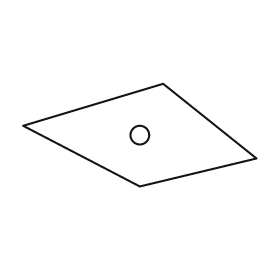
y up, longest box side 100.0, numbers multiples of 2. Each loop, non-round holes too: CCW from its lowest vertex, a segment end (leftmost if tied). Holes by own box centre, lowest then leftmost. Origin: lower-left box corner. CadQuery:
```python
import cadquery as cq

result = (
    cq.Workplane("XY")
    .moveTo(50.0, 0.0)
    .lineTo(100.0, 12.0)
    .lineTo(60.0, 44.0)
    .lineTo(0.0, 26.0)
    .close()
    .moveTo(50.0, 22.0)
    .circle(4.0)
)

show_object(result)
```